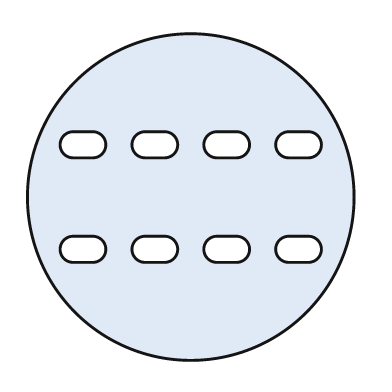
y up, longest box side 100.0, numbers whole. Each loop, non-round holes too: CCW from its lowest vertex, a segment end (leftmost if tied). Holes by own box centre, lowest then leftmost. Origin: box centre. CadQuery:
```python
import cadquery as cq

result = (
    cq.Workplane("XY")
    .moveTo(0.0, 0.0)
    .circle(50.0)
    .moveTo(-36.0, -20.0)
    .lineTo(-30.0, -20.0)
    .threePointArc((-26.0, -16.0), (-30.0, -12.0))
    .lineTo(-36.0, -12.0)
    .threePointArc((-40.0, -16.0), (-36.0, -20.0))
    .close()
    .moveTo(-14.0, -20.0)
    .lineTo(-8.0, -20.0)
    .threePointArc((-4.0, -16.0), (-8.0, -12.0))
    .lineTo(-14.0, -12.0)
    .threePointArc((-18.0, -16.0), (-14.0, -20.0))
    .close()
    .moveTo(8.0, -20.0)
    .lineTo(14.0, -20.0)
    .threePointArc((18.0, -16.0), (14.0, -12.0))
    .lineTo(8.0, -12.0)
    .threePointArc((4.0, -16.0), (8.0, -20.0))
    .close()
    .moveTo(30.0, -20.0)
    .lineTo(36.0, -20.0)
    .threePointArc((40.0, -16.0), (36.0, -12.0))
    .lineTo(30.0, -12.0)
    .threePointArc((26.0, -16.0), (30.0, -20.0))
    .close()
    .moveTo(-36.0, 12.0)
    .lineTo(-30.0, 12.0)
    .threePointArc((-26.0, 16.0), (-30.0, 20.0))
    .lineTo(-36.0, 20.0)
    .threePointArc((-40.0, 16.0), (-36.0, 12.0))
    .close()
    .moveTo(-14.0, 12.0)
    .lineTo(-8.0, 12.0)
    .threePointArc((-4.0, 16.0), (-8.0, 20.0))
    .lineTo(-14.0, 20.0)
    .threePointArc((-18.0, 16.0), (-14.0, 12.0))
    .close()
    .moveTo(8.0, 12.0)
    .lineTo(14.0, 12.0)
    .threePointArc((18.0, 16.0), (14.0, 20.0))
    .lineTo(8.0, 20.0)
    .threePointArc((4.0, 16.0), (8.0, 12.0))
    .close()
    .moveTo(30.0, 12.0)
    .lineTo(36.0, 12.0)
    .threePointArc((40.0, 16.0), (36.0, 20.0))
    .lineTo(30.0, 20.0)
    .threePointArc((26.0, 16.0), (30.0, 12.0))
    .close()
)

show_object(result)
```